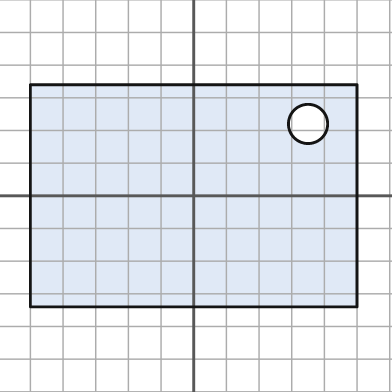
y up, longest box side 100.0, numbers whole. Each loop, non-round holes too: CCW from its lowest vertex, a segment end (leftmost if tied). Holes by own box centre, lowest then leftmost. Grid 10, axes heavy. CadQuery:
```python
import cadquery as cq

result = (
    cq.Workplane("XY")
    .moveTo(-50.0, -34.0)
    .lineTo(50.0, -34.0)
    .lineTo(50.0, 34.0)
    .lineTo(-50.0, 34.0)
    .close()
    .moveTo(35.0, 22.0)
    .circle(6.0)
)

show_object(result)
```